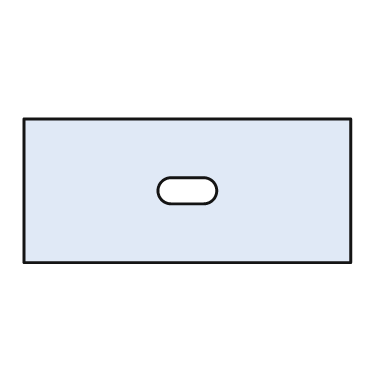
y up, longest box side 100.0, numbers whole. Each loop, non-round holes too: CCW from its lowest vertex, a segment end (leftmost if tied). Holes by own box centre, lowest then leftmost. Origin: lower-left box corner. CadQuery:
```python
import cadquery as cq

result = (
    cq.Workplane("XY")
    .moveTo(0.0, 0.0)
    .lineTo(100.0, 0.0)
    .lineTo(100.0, 44.0)
    .lineTo(0.0, 44.0)
    .close()
    .moveTo(45.0, 18.0)
    .lineTo(55.0, 18.0)
    .threePointArc((59.0, 22.0), (55.0, 26.0))
    .lineTo(45.0, 26.0)
    .threePointArc((41.0, 22.0), (45.0, 18.0))
    .close()
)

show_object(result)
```